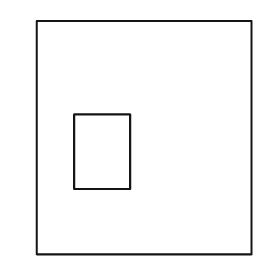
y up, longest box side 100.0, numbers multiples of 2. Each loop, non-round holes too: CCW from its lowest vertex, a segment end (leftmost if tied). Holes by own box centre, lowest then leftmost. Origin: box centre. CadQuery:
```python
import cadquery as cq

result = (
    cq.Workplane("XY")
    .moveTo(-46.0, -50.0)
    .lineTo(46.0, -50.0)
    .lineTo(46.0, 50.0)
    .lineTo(-46.0, 50.0)
    .close()
    .moveTo(-30.0, -22.0)
    .lineTo(-6.0, -22.0)
    .lineTo(-6.0, 10.0)
    .lineTo(-30.0, 10.0)
    .close()
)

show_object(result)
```